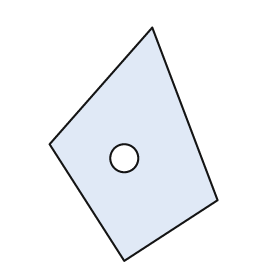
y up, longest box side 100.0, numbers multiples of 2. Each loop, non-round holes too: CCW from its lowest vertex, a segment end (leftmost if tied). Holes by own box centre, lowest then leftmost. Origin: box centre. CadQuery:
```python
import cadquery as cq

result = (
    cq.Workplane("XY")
    .moveTo(-4.0, -50.0)
    .lineTo(36.0, -24.0)
    .lineTo(8.0, 50.0)
    .lineTo(-36.0, 0.0)
    .close()
    .moveTo(-4.0, -6.0)
    .circle(6.0)
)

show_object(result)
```